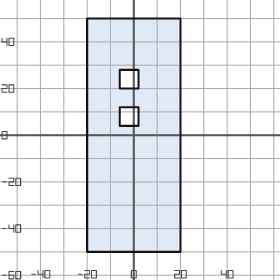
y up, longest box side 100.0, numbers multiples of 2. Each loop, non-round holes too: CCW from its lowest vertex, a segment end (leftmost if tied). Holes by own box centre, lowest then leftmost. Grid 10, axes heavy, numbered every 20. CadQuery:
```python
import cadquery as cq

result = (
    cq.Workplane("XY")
    .moveTo(-20.0, -50.0)
    .lineTo(20.0, -50.0)
    .lineTo(20.0, 50.0)
    .lineTo(-20.0, 50.0)
    .close()
    .moveTo(-6.0, 4.0)
    .lineTo(2.0, 4.0)
    .lineTo(2.0, 12.0)
    .lineTo(-6.0, 12.0)
    .close()
    .moveTo(-6.0, 20.0)
    .lineTo(2.0, 20.0)
    .lineTo(2.0, 28.0)
    .lineTo(-6.0, 28.0)
    .close()
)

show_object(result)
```